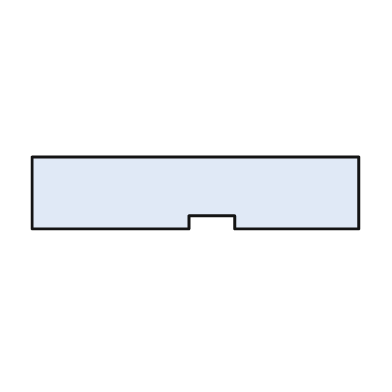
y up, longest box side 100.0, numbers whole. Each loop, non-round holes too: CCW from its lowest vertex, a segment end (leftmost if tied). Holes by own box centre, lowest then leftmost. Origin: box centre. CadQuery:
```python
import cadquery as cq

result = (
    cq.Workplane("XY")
    .moveTo(-50.0, -11.0)
    .lineTo(-2.0, -11.0)
    .lineTo(-2.0, -7.0)
    .lineTo(12.0, -7.0)
    .lineTo(12.0, -11.0)
    .lineTo(50.0, -11.0)
    .lineTo(50.0, 11.0)
    .lineTo(-50.0, 11.0)
    .close()
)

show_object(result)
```